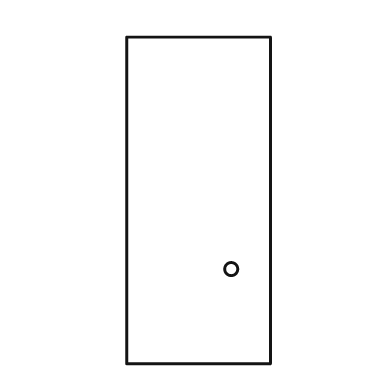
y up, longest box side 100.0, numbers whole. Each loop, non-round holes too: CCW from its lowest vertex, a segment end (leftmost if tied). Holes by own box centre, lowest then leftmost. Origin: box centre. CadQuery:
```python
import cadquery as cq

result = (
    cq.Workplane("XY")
    .moveTo(-22.0, -50.0)
    .lineTo(22.0, -50.0)
    .lineTo(22.0, 50.0)
    .lineTo(-22.0, 50.0)
    .close()
    .moveTo(10.0, -21.0)
    .circle(2.0)
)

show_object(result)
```